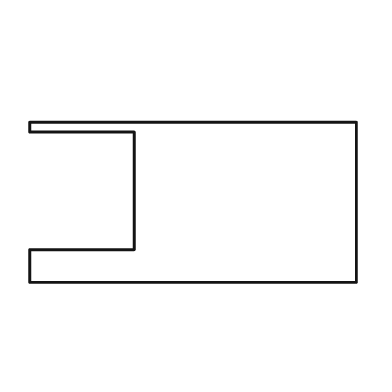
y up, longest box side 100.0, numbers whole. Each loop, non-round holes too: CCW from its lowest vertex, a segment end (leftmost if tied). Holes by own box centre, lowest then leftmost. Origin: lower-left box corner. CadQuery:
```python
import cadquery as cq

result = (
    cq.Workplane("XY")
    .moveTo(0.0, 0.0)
    .lineTo(100.0, 0.0)
    .lineTo(100.0, 49.0)
    .lineTo(0.0, 49.0)
    .lineTo(0.0, 46.0)
    .lineTo(32.0, 46.0)
    .lineTo(32.0, 10.0)
    .lineTo(0.0, 10.0)
    .close()
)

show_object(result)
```